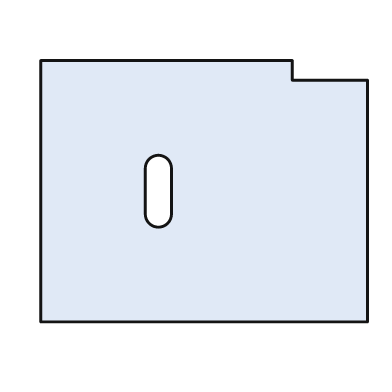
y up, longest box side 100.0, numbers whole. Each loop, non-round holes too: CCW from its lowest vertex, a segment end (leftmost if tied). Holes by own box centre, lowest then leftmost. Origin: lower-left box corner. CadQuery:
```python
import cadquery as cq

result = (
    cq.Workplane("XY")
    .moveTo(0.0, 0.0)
    .lineTo(100.0, 0.0)
    .lineTo(100.0, 74.0)
    .lineTo(77.0, 74.0)
    .lineTo(77.0, 80.0)
    .lineTo(0.0, 80.0)
    .close()
    .moveTo(32.0, 33.0)
    .threePointArc((36.0, 29.0), (40.0, 33.0))
    .lineTo(40.0, 47.0)
    .threePointArc((36.0, 51.0), (32.0, 47.0))
    .close()
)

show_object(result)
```